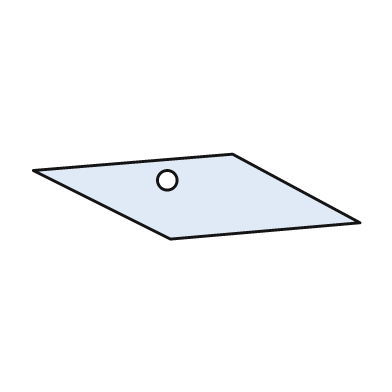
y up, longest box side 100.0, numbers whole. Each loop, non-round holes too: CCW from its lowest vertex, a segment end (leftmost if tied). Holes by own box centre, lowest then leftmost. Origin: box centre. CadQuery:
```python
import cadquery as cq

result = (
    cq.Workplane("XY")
    .moveTo(-8.0, -13.0)
    .lineTo(50.0, -8.0)
    .lineTo(11.0, 13.0)
    .lineTo(-50.0, 8.0)
    .close()
    .moveTo(-9.0, 5.0)
    .circle(3.0)
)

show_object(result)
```